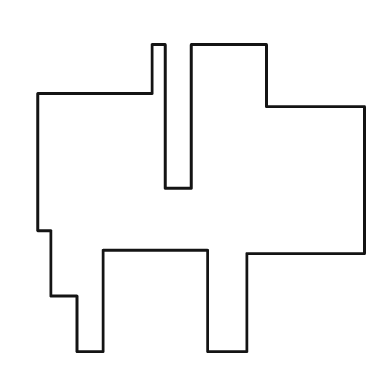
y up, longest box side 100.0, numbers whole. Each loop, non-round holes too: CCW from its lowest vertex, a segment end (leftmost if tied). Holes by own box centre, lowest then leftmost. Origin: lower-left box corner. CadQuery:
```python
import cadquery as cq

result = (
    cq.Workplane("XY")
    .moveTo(12.0, 0.0)
    .lineTo(20.0, 0.0)
    .lineTo(20.0, 31.0)
    .lineTo(52.0, 31.0)
    .lineTo(52.0, 0.0)
    .lineTo(64.0, 0.0)
    .lineTo(64.0, 30.0)
    .lineTo(100.0, 30.0)
    .lineTo(100.0, 75.0)
    .lineTo(70.0, 75.0)
    .lineTo(70.0, 94.0)
    .lineTo(47.0, 94.0)
    .lineTo(47.0, 50.0)
    .lineTo(39.0, 50.0)
    .lineTo(39.0, 94.0)
    .lineTo(35.0, 94.0)
    .lineTo(35.0, 79.0)
    .lineTo(0.0, 79.0)
    .lineTo(0.0, 37.0)
    .lineTo(4.0, 37.0)
    .lineTo(4.0, 17.0)
    .lineTo(12.0, 17.0)
    .close()
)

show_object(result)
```